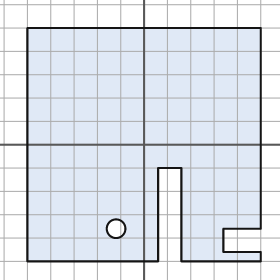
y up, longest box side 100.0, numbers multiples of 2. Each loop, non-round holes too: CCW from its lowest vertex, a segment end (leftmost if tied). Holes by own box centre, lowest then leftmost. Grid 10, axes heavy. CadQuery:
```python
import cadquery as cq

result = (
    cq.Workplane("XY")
    .moveTo(-50.0, -50.0)
    .lineTo(6.0, -50.0)
    .lineTo(6.0, -10.0)
    .lineTo(16.0, -10.0)
    .lineTo(16.0, -50.0)
    .lineTo(50.0, -50.0)
    .lineTo(50.0, -46.0)
    .lineTo(34.0, -46.0)
    .lineTo(34.0, -36.0)
    .lineTo(50.0, -36.0)
    .lineTo(50.0, 50.0)
    .lineTo(-50.0, 50.0)
    .close()
    .moveTo(-12.0, -36.0)
    .circle(4.0)
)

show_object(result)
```